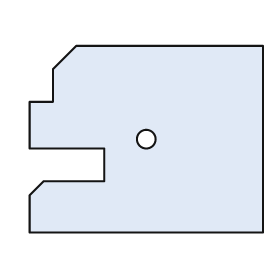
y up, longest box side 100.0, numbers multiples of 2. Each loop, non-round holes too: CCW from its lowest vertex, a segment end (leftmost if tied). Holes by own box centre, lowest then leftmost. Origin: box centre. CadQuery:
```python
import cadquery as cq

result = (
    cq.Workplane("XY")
    .moveTo(-50.0, -40.0)
    .lineTo(50.0, -40.0)
    .lineTo(50.0, 40.0)
    .lineTo(-30.0, 40.0)
    .lineTo(-40.0, 30.0)
    .lineTo(-40.0, 16.0)
    .lineTo(-50.0, 16.0)
    .lineTo(-50.0, -4.0)
    .lineTo(-18.0, -4.0)
    .lineTo(-18.0, -18.0)
    .lineTo(-44.0, -18.0)
    .lineTo(-50.0, -24.0)
    .close()
    .moveTo(0.0, 0.0)
    .circle(4.0)
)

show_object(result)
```